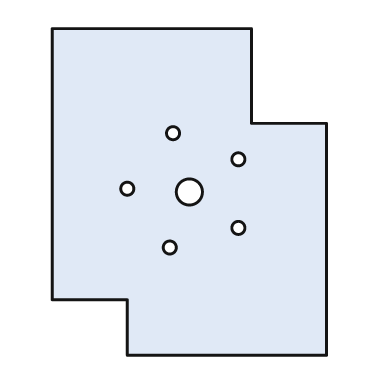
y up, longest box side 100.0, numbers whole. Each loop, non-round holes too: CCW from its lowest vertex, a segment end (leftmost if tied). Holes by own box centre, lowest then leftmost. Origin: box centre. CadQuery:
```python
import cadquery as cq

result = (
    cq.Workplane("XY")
    .moveTo(-19.0, -50.0)
    .lineTo(42.0, -50.0)
    .lineTo(42.0, 21.0)
    .lineTo(19.0, 21.0)
    .lineTo(19.0, 50.0)
    .lineTo(-42.0, 50.0)
    .lineTo(-42.0, -33.0)
    .lineTo(-19.0, -33.0)
    .close()
    .moveTo(-6.0, -17.0)
    .circle(2.0)
    .moveTo(15.0, -11.0)
    .circle(2.0)
    .moveTo(0.0, 0.0)
    .circle(4.0)
    .moveTo(-19.0, 1.0)
    .circle(2.0)
    .moveTo(15.0, 10.0)
    .circle(2.0)
    .moveTo(-5.0, 18.0)
    .circle(2.0)
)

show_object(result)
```